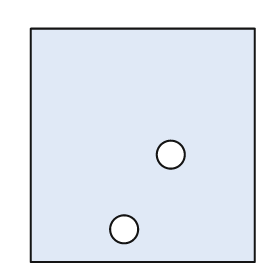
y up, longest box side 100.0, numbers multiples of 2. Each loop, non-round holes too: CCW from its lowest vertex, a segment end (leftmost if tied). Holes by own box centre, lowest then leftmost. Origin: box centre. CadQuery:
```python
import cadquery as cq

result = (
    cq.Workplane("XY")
    .moveTo(-48.0, -50.0)
    .lineTo(48.0, -50.0)
    .lineTo(48.0, 50.0)
    .lineTo(-48.0, 50.0)
    .close()
    .moveTo(-8.0, -36.0)
    .circle(6.0)
    .moveTo(12.0, -4.0)
    .circle(6.0)
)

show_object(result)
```